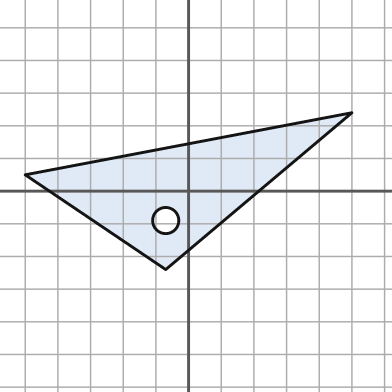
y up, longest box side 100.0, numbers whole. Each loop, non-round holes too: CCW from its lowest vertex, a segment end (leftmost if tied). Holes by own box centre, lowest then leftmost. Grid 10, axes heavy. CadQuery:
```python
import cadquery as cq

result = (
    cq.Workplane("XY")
    .moveTo(-7.0, -24.0)
    .lineTo(50.0, 24.0)
    .lineTo(-50.0, 5.0)
    .close()
    .moveTo(-7.0, -9.0)
    .circle(4.0)
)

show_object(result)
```